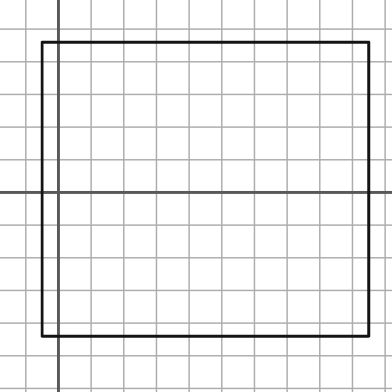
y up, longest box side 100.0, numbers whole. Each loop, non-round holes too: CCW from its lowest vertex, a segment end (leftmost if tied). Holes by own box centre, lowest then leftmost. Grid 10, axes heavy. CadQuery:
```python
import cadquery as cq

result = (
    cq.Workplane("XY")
    .moveTo(-5.0, -44.0)
    .lineTo(95.0, -44.0)
    .lineTo(95.0, 46.0)
    .lineTo(-5.0, 46.0)
    .close()
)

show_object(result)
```